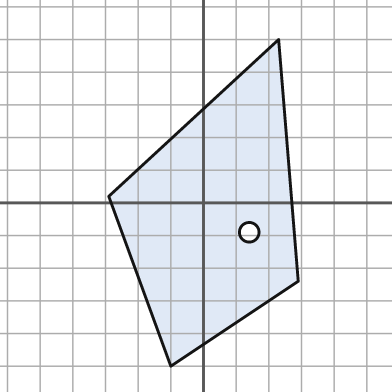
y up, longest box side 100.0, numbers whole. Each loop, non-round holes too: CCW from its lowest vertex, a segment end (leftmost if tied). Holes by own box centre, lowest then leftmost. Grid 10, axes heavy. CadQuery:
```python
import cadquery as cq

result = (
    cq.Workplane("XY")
    .moveTo(-10.0, -50.0)
    .lineTo(29.0, -24.0)
    .lineTo(23.0, 50.0)
    .lineTo(-29.0, 2.0)
    .close()
    .moveTo(14.0, -9.0)
    .circle(3.0)
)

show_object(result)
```